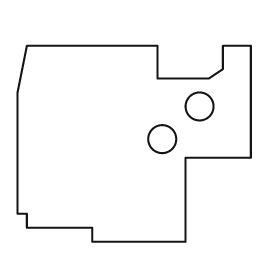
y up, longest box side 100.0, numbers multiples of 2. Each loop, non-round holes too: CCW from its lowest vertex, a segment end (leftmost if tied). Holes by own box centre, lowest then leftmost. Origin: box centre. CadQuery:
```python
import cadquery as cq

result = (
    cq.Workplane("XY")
    .moveTo(-18.0, -42.0)
    .lineTo(22.0, -42.0)
    .lineTo(22.0, -6.0)
    .lineTo(50.0, -6.0)
    .lineTo(50.0, 42.0)
    .lineTo(38.0, 42.0)
    .lineTo(38.0, 32.0)
    .lineTo(32.0, 28.0)
    .lineTo(10.0, 28.0)
    .lineTo(10.0, 42.0)
    .lineTo(-46.0, 42.0)
    .lineTo(-50.0, 22.0)
    .lineTo(-50.0, -30.0)
    .lineTo(-46.0, -30.0)
    .lineTo(-46.0, -36.0)
    .lineTo(-18.0, -36.0)
    .close()
    .moveTo(12.0, 2.0)
    .circle(6.0)
    .moveTo(28.0, 16.0)
    .circle(6.0)
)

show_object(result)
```